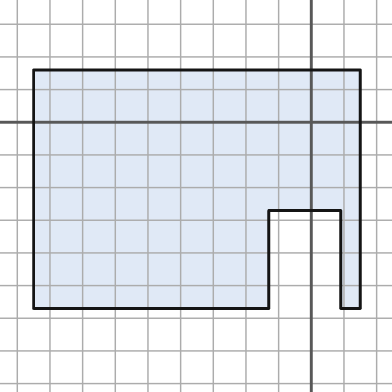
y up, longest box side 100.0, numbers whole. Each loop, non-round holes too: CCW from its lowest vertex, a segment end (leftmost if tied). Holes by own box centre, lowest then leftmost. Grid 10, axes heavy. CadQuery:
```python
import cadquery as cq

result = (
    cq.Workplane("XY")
    .moveTo(-85.0, -57.0)
    .lineTo(-13.0, -57.0)
    .lineTo(-13.0, -27.0)
    .lineTo(9.0, -27.0)
    .lineTo(9.0, -57.0)
    .lineTo(15.0, -57.0)
    .lineTo(15.0, 16.0)
    .lineTo(-85.0, 16.0)
    .close()
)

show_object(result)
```